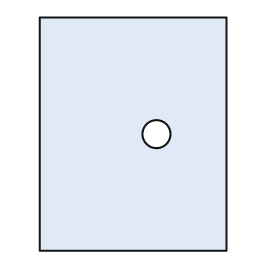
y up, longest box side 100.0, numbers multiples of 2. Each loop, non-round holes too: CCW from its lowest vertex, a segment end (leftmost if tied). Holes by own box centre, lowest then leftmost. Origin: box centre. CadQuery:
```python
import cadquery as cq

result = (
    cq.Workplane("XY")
    .moveTo(-40.0, -50.0)
    .lineTo(40.0, -50.0)
    .lineTo(40.0, 50.0)
    .lineTo(-40.0, 50.0)
    .close()
    .moveTo(10.0, 0.0)
    .circle(6.0)
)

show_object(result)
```